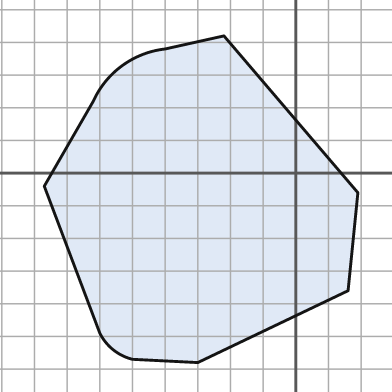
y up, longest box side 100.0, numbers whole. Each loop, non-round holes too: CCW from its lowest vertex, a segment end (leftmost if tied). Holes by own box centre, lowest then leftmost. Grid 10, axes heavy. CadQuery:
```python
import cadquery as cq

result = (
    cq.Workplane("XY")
    .moveTo(-30.0, -58.0)
    .lineTo(16.0, -36.0)
    .lineTo(19.0, -6.0)
    .lineTo(-22.0, 42.0)
    .lineTo(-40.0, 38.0)
    .threePointArc((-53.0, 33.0), (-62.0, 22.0))
    .lineTo(-77.0, -4.0)
    .lineTo(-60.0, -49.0)
    .threePointArc((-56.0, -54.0), (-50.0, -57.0))
    .close()
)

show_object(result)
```